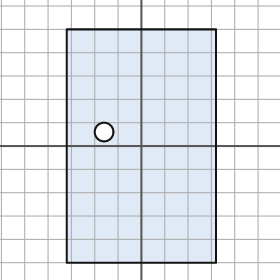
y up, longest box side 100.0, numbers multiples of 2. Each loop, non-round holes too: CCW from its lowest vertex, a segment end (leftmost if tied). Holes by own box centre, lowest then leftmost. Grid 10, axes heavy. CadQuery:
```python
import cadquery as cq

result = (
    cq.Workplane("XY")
    .moveTo(-32.0, -50.0)
    .lineTo(32.0, -50.0)
    .lineTo(32.0, 50.0)
    .lineTo(-32.0, 50.0)
    .close()
    .moveTo(-16.0, 6.0)
    .circle(4.0)
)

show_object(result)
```